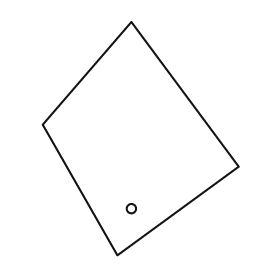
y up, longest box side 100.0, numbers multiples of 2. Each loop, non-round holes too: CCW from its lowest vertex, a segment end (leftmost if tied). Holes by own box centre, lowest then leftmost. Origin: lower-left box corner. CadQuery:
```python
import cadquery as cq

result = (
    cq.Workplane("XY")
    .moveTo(32.0, 0.0)
    .lineTo(84.0, 38.0)
    .lineTo(38.0, 100.0)
    .lineTo(0.0, 56.0)
    .close()
    .moveTo(38.0, 20.0)
    .circle(2.0)
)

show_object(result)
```